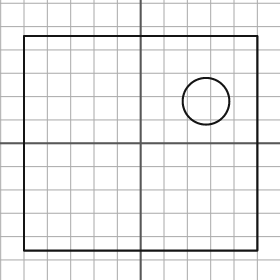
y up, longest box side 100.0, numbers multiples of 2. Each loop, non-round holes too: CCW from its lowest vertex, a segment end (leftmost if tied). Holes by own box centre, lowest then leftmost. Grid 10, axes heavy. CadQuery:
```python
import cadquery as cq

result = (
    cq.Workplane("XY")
    .moveTo(-50.0, -46.0)
    .lineTo(50.0, -46.0)
    .lineTo(50.0, 46.0)
    .lineTo(-50.0, 46.0)
    .close()
    .moveTo(28.0, 18.0)
    .circle(10.0)
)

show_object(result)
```